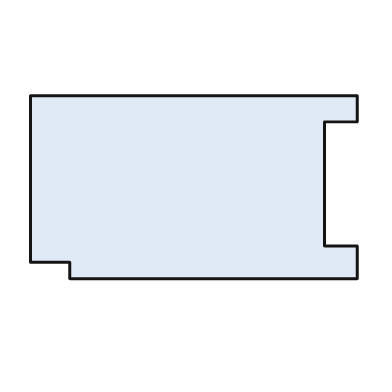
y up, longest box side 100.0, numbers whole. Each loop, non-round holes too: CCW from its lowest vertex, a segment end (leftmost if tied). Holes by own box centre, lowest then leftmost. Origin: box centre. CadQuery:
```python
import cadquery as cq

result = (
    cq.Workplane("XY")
    .moveTo(-38.0, -28.0)
    .lineTo(50.0, -28.0)
    .lineTo(50.0, -18.0)
    .lineTo(40.0, -18.0)
    .lineTo(40.0, 20.0)
    .lineTo(50.0, 20.0)
    .lineTo(50.0, 28.0)
    .lineTo(-50.0, 28.0)
    .lineTo(-50.0, -23.0)
    .lineTo(-38.0, -23.0)
    .close()
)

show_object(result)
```